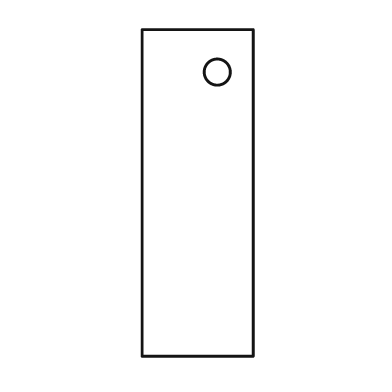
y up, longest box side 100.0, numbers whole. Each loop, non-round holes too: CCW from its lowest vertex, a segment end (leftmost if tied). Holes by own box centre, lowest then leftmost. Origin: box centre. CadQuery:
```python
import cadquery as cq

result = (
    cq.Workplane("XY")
    .moveTo(-17.0, -50.0)
    .lineTo(17.0, -50.0)
    .lineTo(17.0, 50.0)
    .lineTo(-17.0, 50.0)
    .close()
    .moveTo(6.0, 37.0)
    .circle(4.0)
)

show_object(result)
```